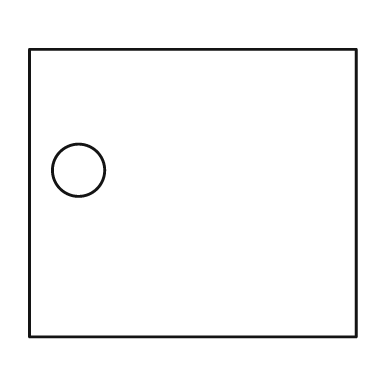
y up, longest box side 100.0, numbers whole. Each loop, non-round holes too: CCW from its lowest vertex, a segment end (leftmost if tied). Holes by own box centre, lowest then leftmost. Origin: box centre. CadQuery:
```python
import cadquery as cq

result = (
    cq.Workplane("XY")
    .moveTo(-50.0, -44.0)
    .lineTo(50.0, -44.0)
    .lineTo(50.0, 44.0)
    .lineTo(-50.0, 44.0)
    .close()
    .moveTo(-35.0, 7.0)
    .circle(8.0)
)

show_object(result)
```